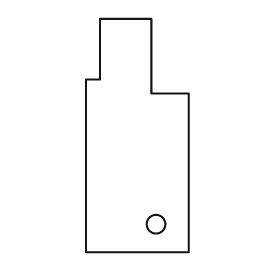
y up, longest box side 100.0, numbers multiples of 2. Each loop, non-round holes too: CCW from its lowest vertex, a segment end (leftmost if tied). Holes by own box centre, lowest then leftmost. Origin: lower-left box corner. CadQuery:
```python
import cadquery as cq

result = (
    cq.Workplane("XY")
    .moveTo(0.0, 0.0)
    .lineTo(44.0, 0.0)
    .lineTo(44.0, 68.0)
    .lineTo(28.0, 68.0)
    .lineTo(28.0, 100.0)
    .lineTo(6.0, 100.0)
    .lineTo(6.0, 74.0)
    .lineTo(0.0, 74.0)
    .close()
    .moveTo(30.0, 12.0)
    .circle(4.0)
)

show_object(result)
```